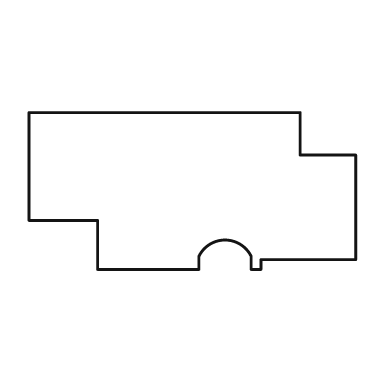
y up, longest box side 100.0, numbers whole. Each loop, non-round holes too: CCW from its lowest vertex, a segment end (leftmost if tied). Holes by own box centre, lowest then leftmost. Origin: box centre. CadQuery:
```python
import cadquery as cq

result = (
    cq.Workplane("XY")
    .moveTo(-29.0, -24.0)
    .lineTo(2.0, -24.0)
    .lineTo(2.0, -20.0)
    .threePointArc((10.0, -15.0), (18.0, -20.0))
    .lineTo(18.0, -24.0)
    .lineTo(21.0, -24.0)
    .lineTo(21.0, -21.0)
    .lineTo(50.0, -21.0)
    .lineTo(50.0, 11.0)
    .lineTo(33.0, 11.0)
    .lineTo(33.0, 24.0)
    .lineTo(-50.0, 24.0)
    .lineTo(-50.0, -9.0)
    .lineTo(-29.0, -9.0)
    .close()
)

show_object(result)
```